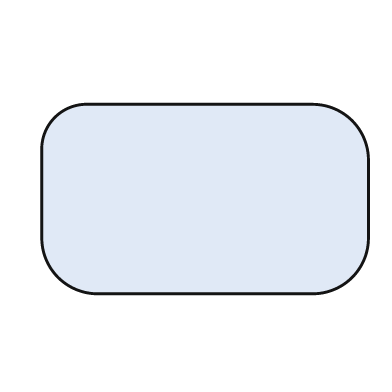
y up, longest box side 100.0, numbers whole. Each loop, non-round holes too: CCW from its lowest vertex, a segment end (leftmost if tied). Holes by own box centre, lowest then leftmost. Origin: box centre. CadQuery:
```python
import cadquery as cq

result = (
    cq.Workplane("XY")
    .moveTo(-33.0, -29.0)
    .lineTo(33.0, -29.0)
    .threePointArc((45.0, -24.0), (50.0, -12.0))
    .lineTo(50.0, 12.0)
    .threePointArc((45.0, 24.0), (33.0, 29.0))
    .lineTo(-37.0, 29.0)
    .threePointArc((-46.0, 25.0), (-50.0, 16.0))
    .lineTo(-50.0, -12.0)
    .threePointArc((-45.0, -24.0), (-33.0, -29.0))
    .close()
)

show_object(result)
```